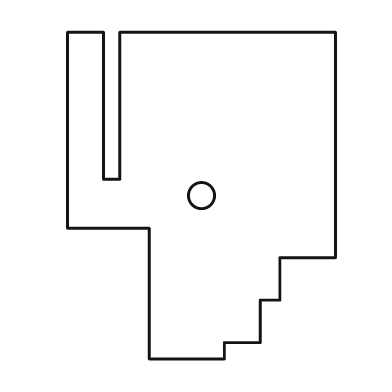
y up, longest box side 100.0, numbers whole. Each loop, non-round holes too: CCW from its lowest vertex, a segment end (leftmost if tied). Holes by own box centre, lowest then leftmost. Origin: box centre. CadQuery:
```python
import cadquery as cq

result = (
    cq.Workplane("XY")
    .moveTo(-16.0, -50.0)
    .lineTo(7.0, -50.0)
    .lineTo(7.0, -45.0)
    .lineTo(18.0, -45.0)
    .lineTo(18.0, -32.0)
    .lineTo(24.0, -32.0)
    .lineTo(24.0, -19.0)
    .lineTo(41.0, -19.0)
    .lineTo(41.0, 50.0)
    .lineTo(-25.0, 50.0)
    .lineTo(-25.0, 5.0)
    .lineTo(-30.0, 5.0)
    .lineTo(-30.0, 50.0)
    .lineTo(-41.0, 50.0)
    .lineTo(-41.0, -10.0)
    .lineTo(-16.0, -10.0)
    .close()
    .moveTo(0.0, 0.0)
    .circle(4.0)
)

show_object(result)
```